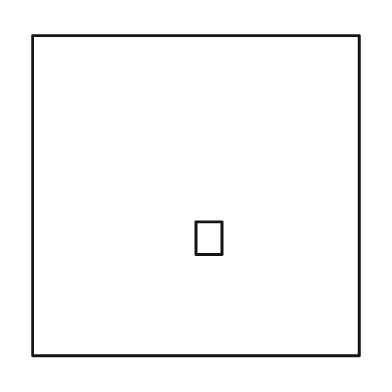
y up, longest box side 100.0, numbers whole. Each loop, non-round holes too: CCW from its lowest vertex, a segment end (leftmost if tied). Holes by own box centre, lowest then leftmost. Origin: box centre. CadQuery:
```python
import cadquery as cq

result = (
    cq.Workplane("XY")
    .moveTo(-50.0, -49.0)
    .lineTo(50.0, -49.0)
    .lineTo(50.0, 49.0)
    .lineTo(-50.0, 49.0)
    .close()
    .moveTo(0.0, -18.0)
    .lineTo(8.0, -18.0)
    .lineTo(8.0, -8.0)
    .lineTo(0.0, -8.0)
    .close()
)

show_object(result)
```